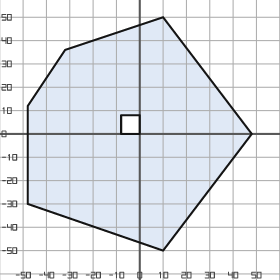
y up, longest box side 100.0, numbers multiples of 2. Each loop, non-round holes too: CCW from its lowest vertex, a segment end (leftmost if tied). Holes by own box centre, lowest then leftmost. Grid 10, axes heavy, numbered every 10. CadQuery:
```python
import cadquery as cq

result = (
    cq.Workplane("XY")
    .moveTo(10.0, -50.0)
    .lineTo(48.0, 0.0)
    .lineTo(10.0, 50.0)
    .lineTo(-32.0, 36.0)
    .lineTo(-48.0, 12.0)
    .lineTo(-48.0, -30.0)
    .close()
    .moveTo(-8.0, 0.0)
    .lineTo(0.0, 0.0)
    .lineTo(0.0, 8.0)
    .lineTo(-8.0, 8.0)
    .close()
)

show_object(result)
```